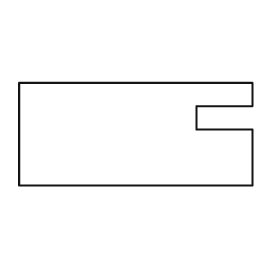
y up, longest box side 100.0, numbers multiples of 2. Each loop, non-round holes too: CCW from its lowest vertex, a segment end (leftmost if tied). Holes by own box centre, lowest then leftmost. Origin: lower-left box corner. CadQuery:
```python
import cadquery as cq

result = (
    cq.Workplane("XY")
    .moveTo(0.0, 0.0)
    .lineTo(100.0, 0.0)
    .lineTo(100.0, 24.0)
    .lineTo(76.0, 24.0)
    .lineTo(76.0, 34.0)
    .lineTo(100.0, 34.0)
    .lineTo(100.0, 44.0)
    .lineTo(0.0, 44.0)
    .close()
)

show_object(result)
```